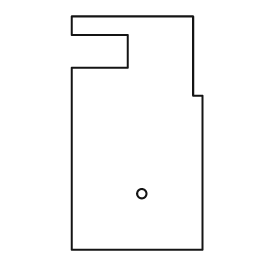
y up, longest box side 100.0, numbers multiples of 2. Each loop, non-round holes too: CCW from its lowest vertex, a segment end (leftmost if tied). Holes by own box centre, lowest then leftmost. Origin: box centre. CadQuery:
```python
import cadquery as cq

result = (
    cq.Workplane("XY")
    .moveTo(-28.0, -50.0)
    .lineTo(28.0, -50.0)
    .lineTo(28.0, 16.0)
    .lineTo(24.0, 16.0)
    .lineTo(24.0, 50.0)
    .lineTo(-28.0, 50.0)
    .lineTo(-28.0, 42.0)
    .lineTo(-4.0, 42.0)
    .lineTo(-4.0, 28.0)
    .lineTo(-28.0, 28.0)
    .close()
    .moveTo(2.0, -26.0)
    .circle(2.0)
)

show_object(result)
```